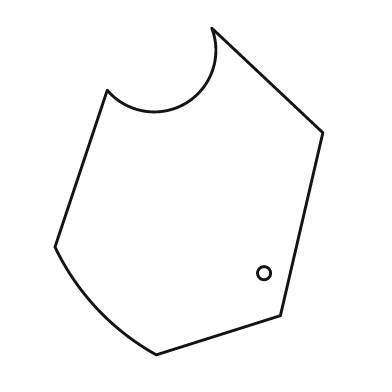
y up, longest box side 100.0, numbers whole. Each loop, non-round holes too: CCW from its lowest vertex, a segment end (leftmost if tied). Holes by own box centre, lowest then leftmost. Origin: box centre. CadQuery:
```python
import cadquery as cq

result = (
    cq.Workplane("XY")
    .moveTo(-10.0, -50.0)
    .lineTo(28.0, -38.0)
    .lineTo(41.0, 18.0)
    .lineTo(7.0, 50.0)
    .threePointArc((-1.0, 27.0), (-25.0, 31.0))
    .lineTo(-41.0, -17.0)
    .threePointArc((-28.0, -36.0), (-10.0, -50.0))
    .close()
    .moveTo(23.0, -25.0)
    .circle(2.0)
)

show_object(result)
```